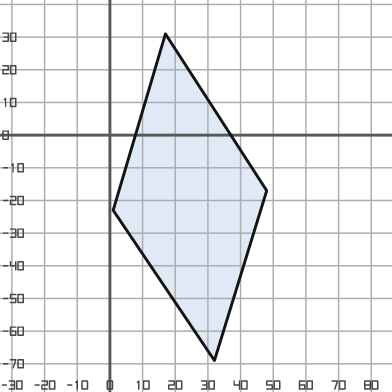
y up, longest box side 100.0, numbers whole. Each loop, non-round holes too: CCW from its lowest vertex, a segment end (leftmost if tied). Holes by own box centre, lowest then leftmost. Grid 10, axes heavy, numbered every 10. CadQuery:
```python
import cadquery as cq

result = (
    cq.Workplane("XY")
    .moveTo(32.0, -69.0)
    .lineTo(48.0, -17.0)
    .lineTo(17.0, 31.0)
    .lineTo(1.0, -23.0)
    .close()
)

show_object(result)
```